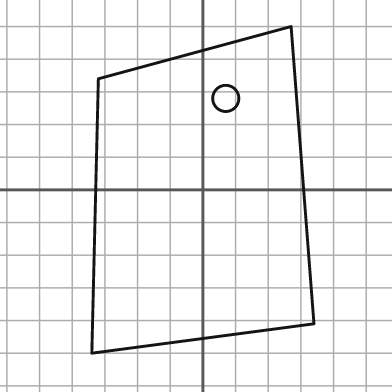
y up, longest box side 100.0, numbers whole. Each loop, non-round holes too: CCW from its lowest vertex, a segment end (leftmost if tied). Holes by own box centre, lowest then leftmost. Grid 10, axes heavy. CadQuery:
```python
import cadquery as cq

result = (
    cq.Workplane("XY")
    .moveTo(-34.0, -50.0)
    .lineTo(34.0, -41.0)
    .lineTo(27.0, 50.0)
    .lineTo(-32.0, 34.0)
    .close()
    .moveTo(7.0, 28.0)
    .circle(4.0)
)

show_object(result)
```